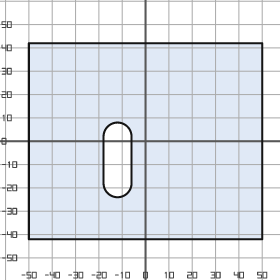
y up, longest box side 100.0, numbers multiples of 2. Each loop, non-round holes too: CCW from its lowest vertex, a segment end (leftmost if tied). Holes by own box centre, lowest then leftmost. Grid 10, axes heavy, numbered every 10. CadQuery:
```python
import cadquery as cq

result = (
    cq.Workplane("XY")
    .moveTo(-50.0, -42.0)
    .lineTo(50.0, -42.0)
    .lineTo(50.0, 42.0)
    .lineTo(-50.0, 42.0)
    .close()
    .moveTo(-18.0, -18.0)
    .threePointArc((-12.0, -24.0), (-6.0, -18.0))
    .lineTo(-6.0, 2.0)
    .threePointArc((-12.0, 8.0), (-18.0, 2.0))
    .close()
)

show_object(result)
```